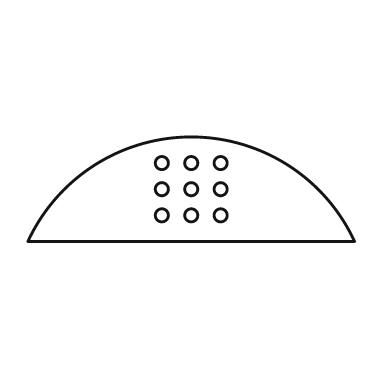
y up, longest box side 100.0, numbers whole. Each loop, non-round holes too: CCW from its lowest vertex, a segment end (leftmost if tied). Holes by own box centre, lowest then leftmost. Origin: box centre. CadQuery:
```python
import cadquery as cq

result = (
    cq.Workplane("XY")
    .moveTo(-50.0, -16.0)
    .lineTo(50.0, -16.0)
    .threePointArc((0.0, 16.0), (-50.0, -16.0))
    .close()
    .moveTo(-9.0, -8.0)
    .circle(2.0)
    .moveTo(0.0, -8.0)
    .circle(2.0)
    .moveTo(9.0, -8.0)
    .circle(2.0)
    .moveTo(-9.0, 0.0)
    .circle(2.0)
    .moveTo(0.0, 0.0)
    .circle(2.0)
    .moveTo(9.0, 0.0)
    .circle(2.0)
    .moveTo(-9.0, 8.0)
    .circle(2.0)
    .moveTo(0.0, 8.0)
    .circle(2.0)
    .moveTo(9.0, 8.0)
    .circle(2.0)
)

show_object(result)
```